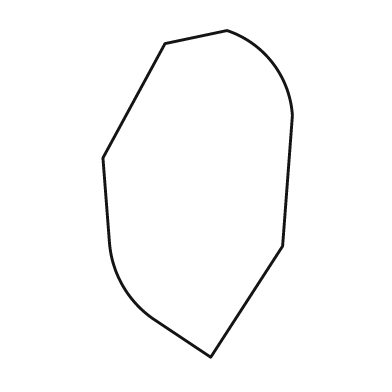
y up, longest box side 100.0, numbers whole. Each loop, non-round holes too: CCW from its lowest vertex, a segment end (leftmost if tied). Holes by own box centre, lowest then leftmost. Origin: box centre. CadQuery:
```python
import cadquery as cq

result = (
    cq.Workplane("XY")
    .moveTo(4.0, -50.0)
    .lineTo(26.0, -16.0)
    .lineTo(29.0, 24.0)
    .threePointArc((23.0, 40.0), (9.0, 50.0))
    .lineTo(-10.0, 46.0)
    .lineTo(-29.0, 11.0)
    .lineTo(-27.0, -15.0)
    .threePointArc((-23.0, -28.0), (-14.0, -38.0))
    .close()
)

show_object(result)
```